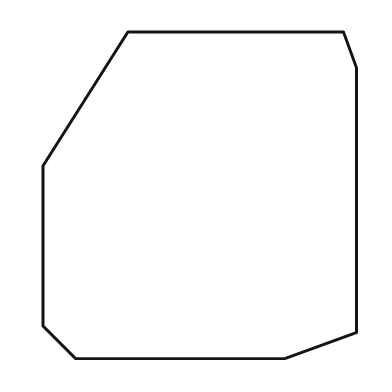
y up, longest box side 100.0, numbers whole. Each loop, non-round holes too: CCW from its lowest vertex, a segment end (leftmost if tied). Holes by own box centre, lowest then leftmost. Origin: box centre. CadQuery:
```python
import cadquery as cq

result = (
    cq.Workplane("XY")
    .moveTo(-38.0, -50.0)
    .lineTo(26.0, -50.0)
    .lineTo(48.0, -42.0)
    .lineTo(48.0, 39.0)
    .lineTo(44.0, 50.0)
    .lineTo(-22.0, 50.0)
    .lineTo(-48.0, 9.0)
    .lineTo(-48.0, -40.0)
    .close()
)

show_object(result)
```